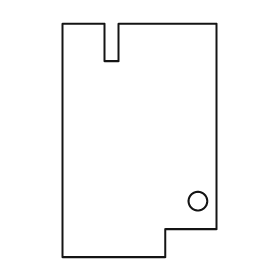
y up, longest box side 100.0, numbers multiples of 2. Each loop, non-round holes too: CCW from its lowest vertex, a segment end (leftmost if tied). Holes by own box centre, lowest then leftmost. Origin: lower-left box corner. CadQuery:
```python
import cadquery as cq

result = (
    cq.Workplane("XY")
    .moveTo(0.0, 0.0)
    .lineTo(44.0, 0.0)
    .lineTo(44.0, 12.0)
    .lineTo(66.0, 12.0)
    .lineTo(66.0, 100.0)
    .lineTo(24.0, 100.0)
    .lineTo(24.0, 84.0)
    .lineTo(18.0, 84.0)
    .lineTo(18.0, 100.0)
    .lineTo(0.0, 100.0)
    .close()
    .moveTo(58.0, 24.0)
    .circle(4.0)
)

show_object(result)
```